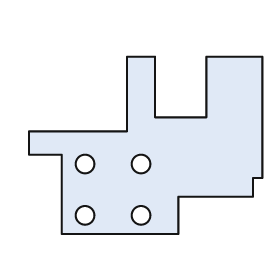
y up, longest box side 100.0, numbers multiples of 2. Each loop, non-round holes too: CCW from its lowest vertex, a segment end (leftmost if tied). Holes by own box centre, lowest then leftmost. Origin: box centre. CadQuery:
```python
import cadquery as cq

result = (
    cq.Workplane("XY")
    .moveTo(-36.0, -38.0)
    .lineTo(14.0, -38.0)
    .lineTo(14.0, -22.0)
    .lineTo(46.0, -22.0)
    .lineTo(46.0, -14.0)
    .lineTo(50.0, -14.0)
    .lineTo(50.0, 38.0)
    .lineTo(26.0, 38.0)
    .lineTo(26.0, 12.0)
    .lineTo(4.0, 12.0)
    .lineTo(4.0, 38.0)
    .lineTo(-8.0, 38.0)
    .lineTo(-8.0, 6.0)
    .lineTo(-50.0, 6.0)
    .lineTo(-50.0, -4.0)
    .lineTo(-36.0, -4.0)
    .close()
    .moveTo(-26.0, -30.0)
    .circle(4.0)
    .moveTo(-2.0, -30.0)
    .circle(4.0)
    .moveTo(-26.0, -8.0)
    .circle(4.0)
    .moveTo(-2.0, -8.0)
    .circle(4.0)
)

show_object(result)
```